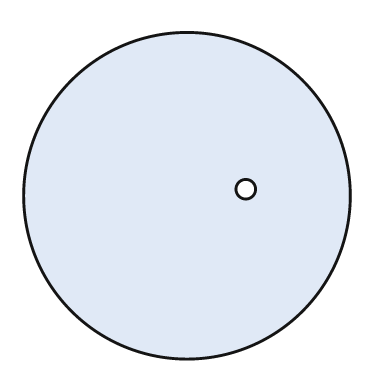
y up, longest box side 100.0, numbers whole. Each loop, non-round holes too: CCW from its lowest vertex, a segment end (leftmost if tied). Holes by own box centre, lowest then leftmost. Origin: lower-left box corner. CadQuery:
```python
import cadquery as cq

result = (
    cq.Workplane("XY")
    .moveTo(50.0, 50.0)
    .circle(50.0)
    .moveTo(68.0, 52.0)
    .circle(3.0)
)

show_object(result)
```